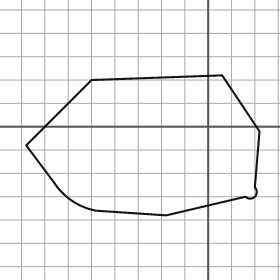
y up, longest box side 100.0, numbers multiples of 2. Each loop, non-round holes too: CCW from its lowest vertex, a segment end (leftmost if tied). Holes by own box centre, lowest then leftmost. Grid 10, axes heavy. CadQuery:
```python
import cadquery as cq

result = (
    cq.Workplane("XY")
    .moveTo(-18.0, -38.0)
    .lineTo(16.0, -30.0)
    .threePointArc((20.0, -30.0), (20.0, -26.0))
    .lineTo(22.0, -2.0)
    .lineTo(6.0, 22.0)
    .lineTo(-50.0, 20.0)
    .lineTo(-78.0, -8.0)
    .lineTo(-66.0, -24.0)
    .threePointArc((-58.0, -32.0), (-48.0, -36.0))
    .close()
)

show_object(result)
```